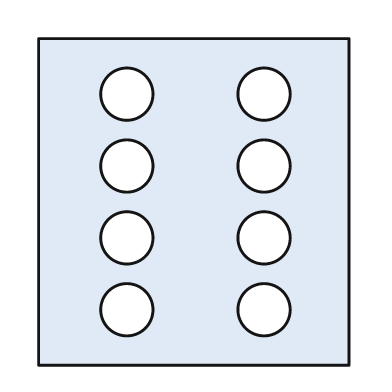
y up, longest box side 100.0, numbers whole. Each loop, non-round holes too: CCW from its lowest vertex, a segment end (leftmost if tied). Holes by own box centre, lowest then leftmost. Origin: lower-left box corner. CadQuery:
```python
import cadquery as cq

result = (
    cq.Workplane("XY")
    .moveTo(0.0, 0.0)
    .lineTo(95.0, 0.0)
    .lineTo(95.0, 100.0)
    .lineTo(0.0, 100.0)
    .close()
    .moveTo(27.0, 17.0)
    .circle(8.0)
    .moveTo(69.0, 17.0)
    .circle(8.0)
    .moveTo(27.0, 39.0)
    .circle(8.0)
    .moveTo(69.0, 39.0)
    .circle(8.0)
    .moveTo(27.0, 61.0)
    .circle(8.0)
    .moveTo(69.0, 61.0)
    .circle(8.0)
    .moveTo(27.0, 83.0)
    .circle(8.0)
    .moveTo(69.0, 83.0)
    .circle(8.0)
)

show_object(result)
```